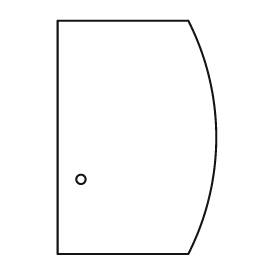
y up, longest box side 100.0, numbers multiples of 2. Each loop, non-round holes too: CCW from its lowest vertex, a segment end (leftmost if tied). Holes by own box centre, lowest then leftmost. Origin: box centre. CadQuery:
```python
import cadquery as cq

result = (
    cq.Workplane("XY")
    .moveTo(-34.0, -50.0)
    .lineTo(22.0, -50.0)
    .threePointArc((34.0, 0.0), (22.0, 50.0))
    .lineTo(-34.0, 50.0)
    .close()
    .moveTo(-24.0, -18.0)
    .circle(2.0)
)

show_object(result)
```